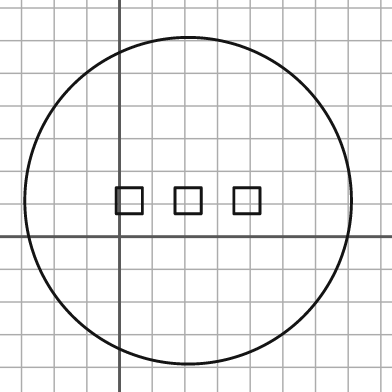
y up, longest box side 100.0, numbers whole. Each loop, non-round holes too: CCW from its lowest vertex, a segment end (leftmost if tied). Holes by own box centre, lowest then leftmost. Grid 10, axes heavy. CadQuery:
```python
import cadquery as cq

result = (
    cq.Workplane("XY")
    .moveTo(21.0, 11.0)
    .circle(50.0)
    .moveTo(-1.0, 7.0)
    .lineTo(7.0, 7.0)
    .lineTo(7.0, 15.0)
    .lineTo(-1.0, 15.0)
    .close()
    .moveTo(17.0, 7.0)
    .lineTo(25.0, 7.0)
    .lineTo(25.0, 15.0)
    .lineTo(17.0, 15.0)
    .close()
    .moveTo(35.0, 7.0)
    .lineTo(43.0, 7.0)
    .lineTo(43.0, 15.0)
    .lineTo(35.0, 15.0)
    .close()
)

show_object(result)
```